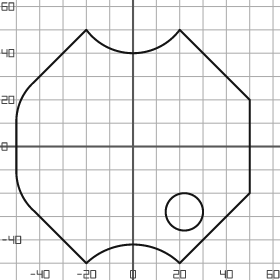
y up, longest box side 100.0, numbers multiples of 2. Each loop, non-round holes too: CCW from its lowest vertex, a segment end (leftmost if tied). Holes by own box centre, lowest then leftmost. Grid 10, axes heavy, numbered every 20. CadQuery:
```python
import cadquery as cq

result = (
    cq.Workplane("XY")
    .moveTo(-20.0, -50.0)
    .threePointArc((0.0, -42.0), (20.0, -50.0))
    .lineTo(50.0, -20.0)
    .lineTo(50.0, 20.0)
    .lineTo(20.0, 50.0)
    .threePointArc((0.0, 40.0), (-20.0, 50.0))
    .lineTo(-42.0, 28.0)
    .threePointArc((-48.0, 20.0), (-50.0, 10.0))
    .lineTo(-50.0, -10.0)
    .threePointArc((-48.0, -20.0), (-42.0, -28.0))
    .close()
    .moveTo(22.0, -28.0)
    .circle(8.0)
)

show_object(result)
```